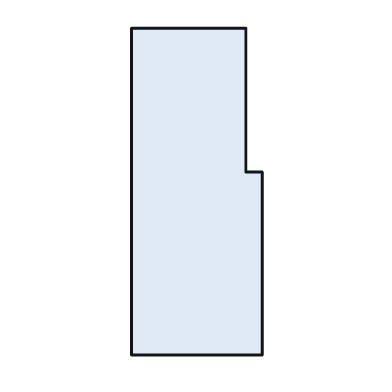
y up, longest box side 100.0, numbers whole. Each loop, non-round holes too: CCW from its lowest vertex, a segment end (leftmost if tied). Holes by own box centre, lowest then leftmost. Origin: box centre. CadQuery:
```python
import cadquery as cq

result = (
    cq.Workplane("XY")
    .moveTo(-20.0, -50.0)
    .lineTo(20.0, -50.0)
    .lineTo(20.0, 6.0)
    .lineTo(15.0, 6.0)
    .lineTo(15.0, 50.0)
    .lineTo(-20.0, 50.0)
    .close()
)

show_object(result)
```